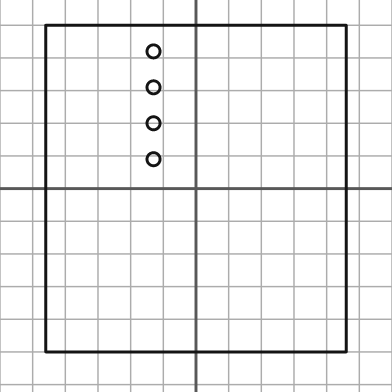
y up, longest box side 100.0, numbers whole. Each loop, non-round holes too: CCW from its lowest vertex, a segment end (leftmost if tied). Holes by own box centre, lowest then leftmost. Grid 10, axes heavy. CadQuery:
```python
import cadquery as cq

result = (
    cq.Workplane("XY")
    .moveTo(-46.0, -50.0)
    .lineTo(46.0, -50.0)
    .lineTo(46.0, 50.0)
    .lineTo(-46.0, 50.0)
    .close()
    .moveTo(-13.0, 9.0)
    .circle(2.0)
    .moveTo(-13.0, 20.0)
    .circle(2.0)
    .moveTo(-13.0, 31.0)
    .circle(2.0)
    .moveTo(-13.0, 42.0)
    .circle(2.0)
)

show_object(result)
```